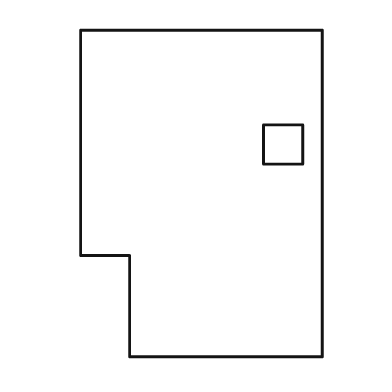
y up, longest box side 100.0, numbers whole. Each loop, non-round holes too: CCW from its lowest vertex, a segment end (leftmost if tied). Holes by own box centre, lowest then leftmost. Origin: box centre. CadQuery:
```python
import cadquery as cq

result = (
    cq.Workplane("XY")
    .moveTo(-22.0, -50.0)
    .lineTo(37.0, -50.0)
    .lineTo(37.0, 50.0)
    .lineTo(-37.0, 50.0)
    .lineTo(-37.0, -19.0)
    .lineTo(-22.0, -19.0)
    .close()
    .moveTo(19.0, 9.0)
    .lineTo(31.0, 9.0)
    .lineTo(31.0, 21.0)
    .lineTo(19.0, 21.0)
    .close()
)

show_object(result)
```